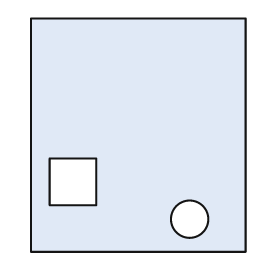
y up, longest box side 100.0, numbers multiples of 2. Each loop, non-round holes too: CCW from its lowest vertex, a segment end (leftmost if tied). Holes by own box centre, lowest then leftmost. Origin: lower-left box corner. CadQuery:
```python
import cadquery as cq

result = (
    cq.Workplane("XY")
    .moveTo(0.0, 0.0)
    .lineTo(92.0, 0.0)
    .lineTo(92.0, 100.0)
    .lineTo(0.0, 100.0)
    .close()
    .moveTo(68.0, 14.0)
    .circle(8.0)
    .moveTo(8.0, 20.0)
    .lineTo(28.0, 20.0)
    .lineTo(28.0, 40.0)
    .lineTo(8.0, 40.0)
    .close()
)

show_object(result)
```